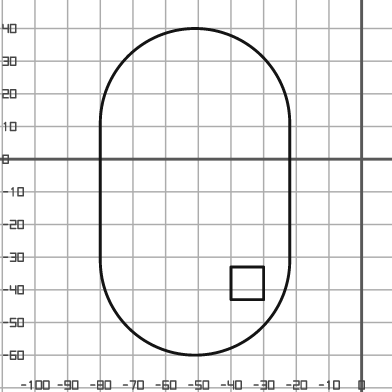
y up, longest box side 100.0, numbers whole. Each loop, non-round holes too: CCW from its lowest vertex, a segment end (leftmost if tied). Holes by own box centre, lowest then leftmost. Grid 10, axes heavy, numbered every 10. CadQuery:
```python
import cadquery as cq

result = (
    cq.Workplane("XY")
    .moveTo(-80.0, -31.0)
    .threePointArc((-51.0, -60.0), (-22.0, -31.0))
    .lineTo(-22.0, 11.0)
    .threePointArc((-51.0, 40.0), (-80.0, 11.0))
    .close()
    .moveTo(-40.0, -43.0)
    .lineTo(-30.0, -43.0)
    .lineTo(-30.0, -33.0)
    .lineTo(-40.0, -33.0)
    .close()
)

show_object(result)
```